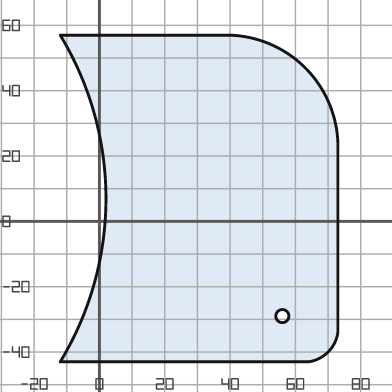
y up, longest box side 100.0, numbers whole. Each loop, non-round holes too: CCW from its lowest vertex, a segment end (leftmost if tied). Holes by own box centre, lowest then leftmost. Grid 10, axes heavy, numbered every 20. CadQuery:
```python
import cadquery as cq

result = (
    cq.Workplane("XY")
    .moveTo(-12.0, -43.0)
    .lineTo(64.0, -43.0)
    .threePointArc((70.0, -40.0), (73.0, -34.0))
    .lineTo(73.0, 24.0)
    .threePointArc((63.0, 47.0), (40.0, 57.0))
    .lineTo(-12.0, 57.0)
    .threePointArc((2.0, 7.0), (-12.0, -43.0))
    .close()
    .moveTo(56.0, -29.0)
    .circle(2.0)
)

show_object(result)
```